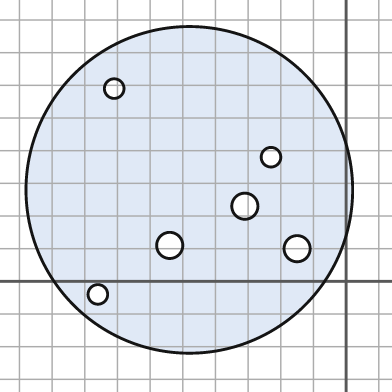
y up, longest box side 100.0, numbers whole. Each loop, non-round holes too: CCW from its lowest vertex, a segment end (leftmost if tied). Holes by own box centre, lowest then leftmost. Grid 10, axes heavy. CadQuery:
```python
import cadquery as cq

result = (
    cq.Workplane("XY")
    .moveTo(-48.0, 28.0)
    .circle(50.0)
    .moveTo(-76.0, -4.0)
    .circle(3.0)
    .moveTo(-15.0, 10.0)
    .circle(4.0)
    .moveTo(-54.0, 11.0)
    .circle(4.0)
    .moveTo(-31.0, 23.0)
    .circle(4.0)
    .moveTo(-23.0, 38.0)
    .circle(3.0)
    .moveTo(-71.0, 59.0)
    .circle(3.0)
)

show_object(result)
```